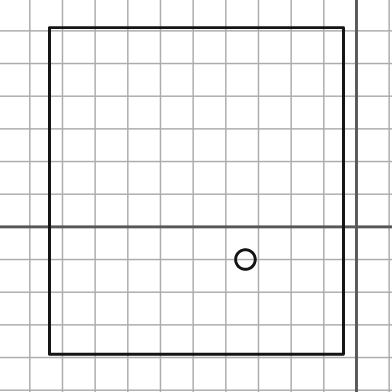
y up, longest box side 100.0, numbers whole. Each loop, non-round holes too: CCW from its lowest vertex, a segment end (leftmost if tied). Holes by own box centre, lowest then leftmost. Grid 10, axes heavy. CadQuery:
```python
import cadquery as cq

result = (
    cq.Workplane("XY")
    .moveTo(-94.0, -39.0)
    .lineTo(-4.0, -39.0)
    .lineTo(-4.0, 61.0)
    .lineTo(-94.0, 61.0)
    .close()
    .moveTo(-34.0, -10.0)
    .circle(3.0)
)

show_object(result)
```